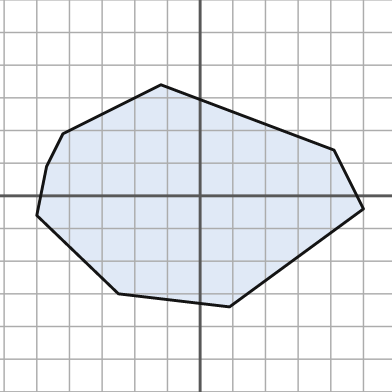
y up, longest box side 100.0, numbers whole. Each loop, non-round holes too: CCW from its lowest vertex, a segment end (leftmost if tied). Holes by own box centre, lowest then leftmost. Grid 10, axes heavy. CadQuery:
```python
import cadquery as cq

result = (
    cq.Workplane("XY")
    .moveTo(9.0, -34.0)
    .lineTo(50.0, -4.0)
    .lineTo(41.0, 14.0)
    .lineTo(-12.0, 34.0)
    .lineTo(-42.0, 19.0)
    .lineTo(-47.0, 9.0)
    .lineTo(-50.0, -6.0)
    .lineTo(-25.0, -30.0)
    .close()
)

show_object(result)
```